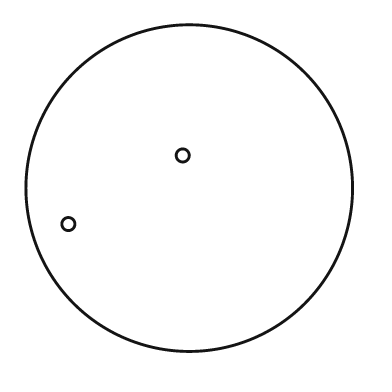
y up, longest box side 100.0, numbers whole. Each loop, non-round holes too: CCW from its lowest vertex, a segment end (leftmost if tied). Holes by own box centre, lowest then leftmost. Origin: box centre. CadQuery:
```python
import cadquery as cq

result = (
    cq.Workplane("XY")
    .moveTo(0.0, 0.0)
    .circle(50.0)
    .moveTo(-37.0, -11.0)
    .circle(2.0)
    .moveTo(-2.0, 10.0)
    .circle(2.0)
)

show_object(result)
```